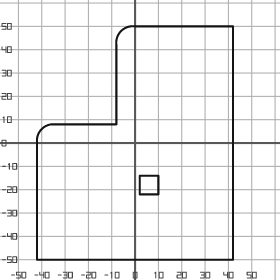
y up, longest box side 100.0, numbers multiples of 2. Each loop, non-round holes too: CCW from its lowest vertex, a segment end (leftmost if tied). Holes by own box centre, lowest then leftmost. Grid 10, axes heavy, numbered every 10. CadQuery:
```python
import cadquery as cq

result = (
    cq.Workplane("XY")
    .moveTo(-42.0, -50.0)
    .lineTo(42.0, -50.0)
    .lineTo(42.0, 50.0)
    .lineTo(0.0, 50.0)
    .threePointArc((-6.0, 48.0), (-8.0, 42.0))
    .lineTo(-8.0, 8.0)
    .lineTo(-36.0, 8.0)
    .threePointArc((-40.0, 6.0), (-42.0, 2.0))
    .close()
    .moveTo(2.0, -22.0)
    .lineTo(10.0, -22.0)
    .lineTo(10.0, -14.0)
    .lineTo(2.0, -14.0)
    .close()
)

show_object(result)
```